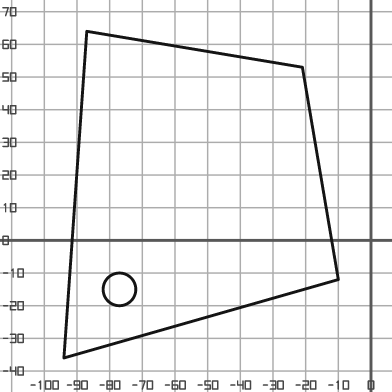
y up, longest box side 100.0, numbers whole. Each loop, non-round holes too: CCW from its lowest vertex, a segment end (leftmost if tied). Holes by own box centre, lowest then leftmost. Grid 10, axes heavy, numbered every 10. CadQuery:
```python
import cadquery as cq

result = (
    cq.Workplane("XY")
    .moveTo(-94.0, -36.0)
    .lineTo(-10.0, -12.0)
    .lineTo(-21.0, 53.0)
    .lineTo(-87.0, 64.0)
    .close()
    .moveTo(-77.0, -15.0)
    .circle(5.0)
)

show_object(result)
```